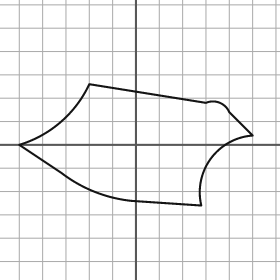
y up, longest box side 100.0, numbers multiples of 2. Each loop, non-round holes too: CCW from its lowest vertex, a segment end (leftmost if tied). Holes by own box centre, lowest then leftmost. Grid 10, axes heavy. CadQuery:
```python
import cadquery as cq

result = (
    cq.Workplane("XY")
    .moveTo(28.0, -26.0)
    .threePointArc((32.0, -6.0), (50.0, 4.0))
    .lineTo(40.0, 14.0)
    .threePointArc((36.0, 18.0), (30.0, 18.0))
    .lineTo(-20.0, 26.0)
    .threePointArc((-32.0, 10.0), (-50.0, 0.0))
    .lineTo(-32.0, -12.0)
    .threePointArc((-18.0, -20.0), (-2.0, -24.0))
    .close()
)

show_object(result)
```